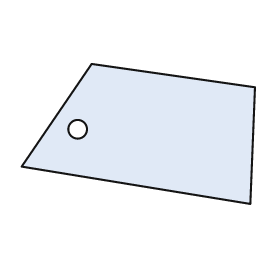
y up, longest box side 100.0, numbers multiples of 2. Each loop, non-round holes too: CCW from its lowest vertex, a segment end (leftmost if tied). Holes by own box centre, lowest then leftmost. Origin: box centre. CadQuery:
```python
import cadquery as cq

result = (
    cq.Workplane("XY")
    .moveTo(48.0, -30.0)
    .lineTo(50.0, 20.0)
    .lineTo(-20.0, 30.0)
    .lineTo(-50.0, -14.0)
    .close()
    .moveTo(-26.0, 2.0)
    .circle(4.0)
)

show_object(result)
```